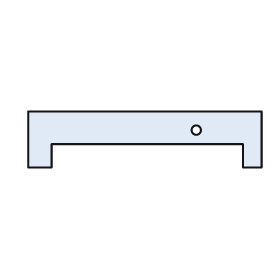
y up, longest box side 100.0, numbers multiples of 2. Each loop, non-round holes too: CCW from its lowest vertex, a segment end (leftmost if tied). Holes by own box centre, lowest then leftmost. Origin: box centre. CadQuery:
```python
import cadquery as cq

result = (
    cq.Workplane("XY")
    .moveTo(-50.0, -12.0)
    .lineTo(-40.0, -12.0)
    .lineTo(-40.0, -2.0)
    .lineTo(42.0, -2.0)
    .lineTo(42.0, -12.0)
    .lineTo(50.0, -12.0)
    .lineTo(50.0, 12.0)
    .lineTo(-50.0, 12.0)
    .close()
    .moveTo(22.0, 4.0)
    .circle(2.0)
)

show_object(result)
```